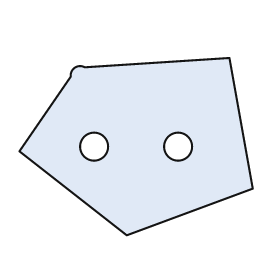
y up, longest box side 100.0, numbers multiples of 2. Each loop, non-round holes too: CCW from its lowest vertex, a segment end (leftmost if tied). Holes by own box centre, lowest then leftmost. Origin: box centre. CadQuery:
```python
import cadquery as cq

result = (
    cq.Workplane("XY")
    .moveTo(-4.0, -38.0)
    .lineTo(50.0, -18.0)
    .lineTo(40.0, 38.0)
    .lineTo(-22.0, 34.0)
    .threePointArc((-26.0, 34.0), (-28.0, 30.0))
    .lineTo(-50.0, -2.0)
    .close()
    .moveTo(-18.0, 0.0)
    .circle(6.0)
    .moveTo(18.0, 0.0)
    .circle(6.0)
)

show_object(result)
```